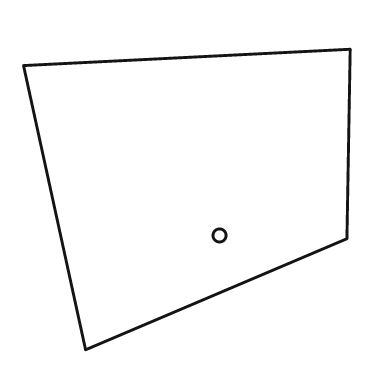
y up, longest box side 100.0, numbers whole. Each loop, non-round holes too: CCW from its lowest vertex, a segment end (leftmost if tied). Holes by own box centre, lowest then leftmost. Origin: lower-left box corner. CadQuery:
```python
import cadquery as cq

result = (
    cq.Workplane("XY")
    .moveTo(19.0, 0.0)
    .lineTo(99.0, 34.0)
    .lineTo(100.0, 92.0)
    .lineTo(0.0, 87.0)
    .close()
    .moveTo(60.0, 35.0)
    .circle(2.0)
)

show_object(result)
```